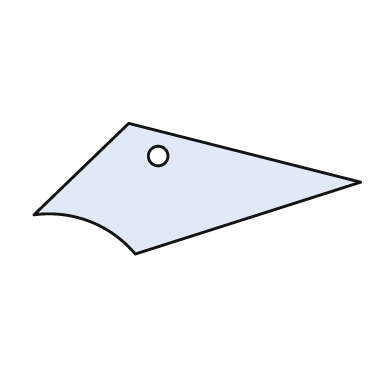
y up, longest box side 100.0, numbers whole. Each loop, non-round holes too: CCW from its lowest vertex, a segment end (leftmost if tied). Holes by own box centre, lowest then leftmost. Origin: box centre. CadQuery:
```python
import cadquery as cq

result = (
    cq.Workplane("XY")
    .moveTo(-19.0, -20.0)
    .lineTo(50.0, 2.0)
    .lineTo(-21.0, 20.0)
    .lineTo(-50.0, -8.0)
    .threePointArc((-33.0, -10.0), (-19.0, -20.0))
    .close()
    .moveTo(-12.0, 10.0)
    .circle(3.0)
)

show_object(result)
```